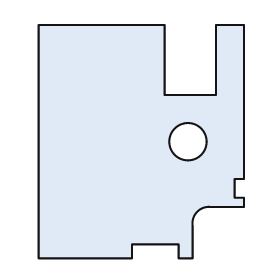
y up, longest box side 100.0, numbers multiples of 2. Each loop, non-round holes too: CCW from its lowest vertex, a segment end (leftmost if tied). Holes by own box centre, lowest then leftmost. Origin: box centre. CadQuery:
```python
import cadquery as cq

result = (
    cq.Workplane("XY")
    .moveTo(-44.0, -50.0)
    .lineTo(-4.0, -50.0)
    .lineTo(-4.0, -44.0)
    .lineTo(16.0, -44.0)
    .lineTo(16.0, -50.0)
    .lineTo(22.0, -50.0)
    .lineTo(22.0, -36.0)
    .threePointArc((24.0, -30.0), (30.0, -28.0))
    .lineTo(44.0, -28.0)
    .lineTo(44.0, -24.0)
    .lineTo(40.0, -24.0)
    .lineTo(40.0, -16.0)
    .lineTo(44.0, -16.0)
    .lineTo(44.0, 50.0)
    .lineTo(32.0, 50.0)
    .lineTo(32.0, 20.0)
    .lineTo(10.0, 20.0)
    .lineTo(10.0, 50.0)
    .lineTo(-44.0, 50.0)
    .close()
    .moveTo(20.0, 0.0)
    .circle(8.0)
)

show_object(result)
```